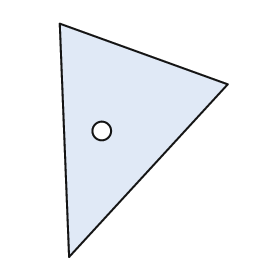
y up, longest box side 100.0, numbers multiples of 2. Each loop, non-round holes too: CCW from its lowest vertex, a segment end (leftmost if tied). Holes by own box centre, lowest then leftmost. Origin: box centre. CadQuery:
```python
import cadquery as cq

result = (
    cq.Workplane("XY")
    .moveTo(-32.0, -50.0)
    .lineTo(36.0, 24.0)
    .lineTo(-36.0, 50.0)
    .close()
    .moveTo(-18.0, 4.0)
    .circle(4.0)
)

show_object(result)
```